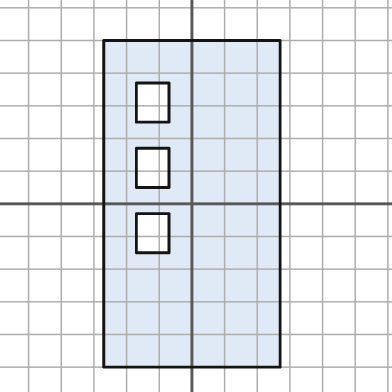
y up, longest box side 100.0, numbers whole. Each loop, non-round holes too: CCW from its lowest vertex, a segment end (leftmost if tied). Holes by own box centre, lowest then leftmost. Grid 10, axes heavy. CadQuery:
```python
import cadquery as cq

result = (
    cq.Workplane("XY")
    .moveTo(-27.0, -50.0)
    .lineTo(27.0, -50.0)
    .lineTo(27.0, 50.0)
    .lineTo(-27.0, 50.0)
    .close()
    .moveTo(-17.0, -15.0)
    .lineTo(-7.0, -15.0)
    .lineTo(-7.0, -3.0)
    .lineTo(-17.0, -3.0)
    .close()
    .moveTo(-17.0, 5.0)
    .lineTo(-7.0, 5.0)
    .lineTo(-7.0, 17.0)
    .lineTo(-17.0, 17.0)
    .close()
    .moveTo(-17.0, 25.0)
    .lineTo(-7.0, 25.0)
    .lineTo(-7.0, 37.0)
    .lineTo(-17.0, 37.0)
    .close()
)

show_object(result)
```